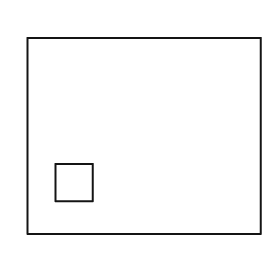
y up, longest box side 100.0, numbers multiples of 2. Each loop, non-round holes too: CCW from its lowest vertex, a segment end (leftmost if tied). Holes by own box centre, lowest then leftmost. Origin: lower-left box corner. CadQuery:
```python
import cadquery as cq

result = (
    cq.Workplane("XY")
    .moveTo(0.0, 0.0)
    .lineTo(100.0, 0.0)
    .lineTo(100.0, 84.0)
    .lineTo(0.0, 84.0)
    .close()
    .moveTo(12.0, 14.0)
    .lineTo(28.0, 14.0)
    .lineTo(28.0, 30.0)
    .lineTo(12.0, 30.0)
    .close()
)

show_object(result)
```